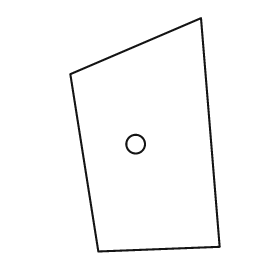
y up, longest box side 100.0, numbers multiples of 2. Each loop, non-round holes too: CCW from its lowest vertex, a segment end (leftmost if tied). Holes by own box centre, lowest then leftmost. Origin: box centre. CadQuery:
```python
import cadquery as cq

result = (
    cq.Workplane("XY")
    .moveTo(-20.0, -50.0)
    .lineTo(32.0, -48.0)
    .lineTo(24.0, 50.0)
    .lineTo(-32.0, 26.0)
    .close()
    .moveTo(-4.0, -4.0)
    .circle(4.0)
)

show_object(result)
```